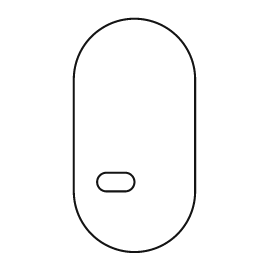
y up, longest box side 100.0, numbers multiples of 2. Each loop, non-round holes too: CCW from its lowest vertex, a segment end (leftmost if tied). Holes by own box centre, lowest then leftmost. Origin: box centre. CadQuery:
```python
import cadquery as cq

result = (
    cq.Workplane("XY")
    .moveTo(-26.0, -24.0)
    .threePointArc((0.0, -50.0), (26.0, -24.0))
    .lineTo(26.0, 24.0)
    .threePointArc((0.0, 50.0), (-26.0, 24.0))
    .close()
    .moveTo(-12.0, -24.0)
    .lineTo(-4.0, -24.0)
    .threePointArc((0.0, -20.0), (-4.0, -16.0))
    .lineTo(-12.0, -16.0)
    .threePointArc((-16.0, -20.0), (-12.0, -24.0))
    .close()
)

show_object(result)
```